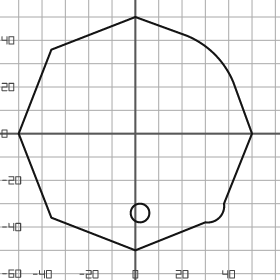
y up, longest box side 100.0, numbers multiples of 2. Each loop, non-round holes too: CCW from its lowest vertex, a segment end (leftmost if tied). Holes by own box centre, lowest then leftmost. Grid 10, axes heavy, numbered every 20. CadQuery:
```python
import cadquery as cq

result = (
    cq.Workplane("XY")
    .moveTo(0.0, -50.0)
    .lineTo(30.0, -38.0)
    .threePointArc((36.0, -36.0), (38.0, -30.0))
    .lineTo(50.0, 0.0)
    .lineTo(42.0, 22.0)
    .threePointArc((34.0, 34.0), (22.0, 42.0))
    .lineTo(0.0, 50.0)
    .lineTo(-36.0, 36.0)
    .lineTo(-50.0, 0.0)
    .lineTo(-36.0, -36.0)
    .close()
    .moveTo(2.0, -34.0)
    .circle(4.0)
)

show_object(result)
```